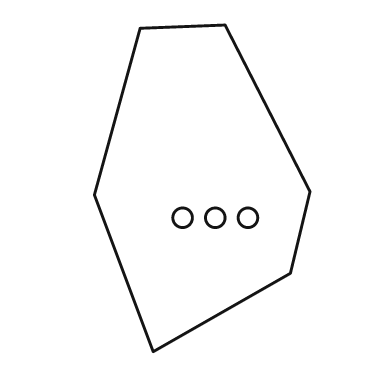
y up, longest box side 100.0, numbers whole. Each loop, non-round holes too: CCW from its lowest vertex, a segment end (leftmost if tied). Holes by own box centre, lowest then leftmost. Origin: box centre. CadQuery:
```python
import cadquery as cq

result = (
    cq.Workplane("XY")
    .moveTo(-15.0, -50.0)
    .lineTo(27.0, -26.0)
    .lineTo(33.0, -1.0)
    .lineTo(7.0, 50.0)
    .lineTo(-19.0, 49.0)
    .lineTo(-33.0, -2.0)
    .close()
    .moveTo(-6.0, -9.0)
    .circle(3.0)
    .moveTo(4.0, -9.0)
    .circle(3.0)
    .moveTo(14.0, -9.0)
    .circle(3.0)
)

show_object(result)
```